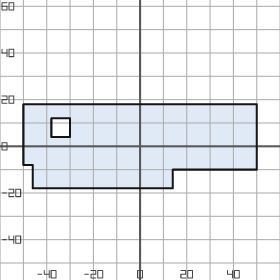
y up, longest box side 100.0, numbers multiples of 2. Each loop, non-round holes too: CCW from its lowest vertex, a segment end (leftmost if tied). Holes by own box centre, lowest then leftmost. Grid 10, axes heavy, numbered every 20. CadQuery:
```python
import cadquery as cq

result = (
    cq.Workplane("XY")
    .moveTo(-46.0, -18.0)
    .lineTo(14.0, -18.0)
    .lineTo(14.0, -10.0)
    .lineTo(50.0, -10.0)
    .lineTo(50.0, 18.0)
    .lineTo(-50.0, 18.0)
    .lineTo(-50.0, -8.0)
    .lineTo(-46.0, -8.0)
    .close()
    .moveTo(-38.0, 4.0)
    .lineTo(-30.0, 4.0)
    .lineTo(-30.0, 12.0)
    .lineTo(-38.0, 12.0)
    .close()
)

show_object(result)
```